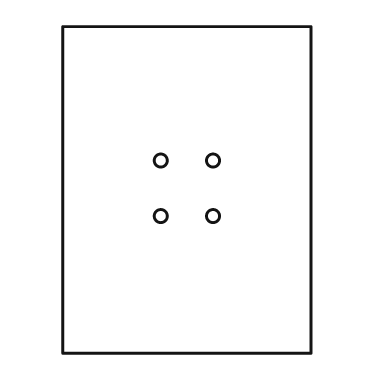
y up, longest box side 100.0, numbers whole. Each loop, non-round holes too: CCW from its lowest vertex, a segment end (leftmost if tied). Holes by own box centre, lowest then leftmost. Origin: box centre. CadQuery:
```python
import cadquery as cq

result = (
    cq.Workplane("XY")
    .moveTo(-38.0, -50.0)
    .lineTo(38.0, -50.0)
    .lineTo(38.0, 50.0)
    .lineTo(-38.0, 50.0)
    .close()
    .moveTo(-8.0, -8.0)
    .circle(2.0)
    .moveTo(8.0, -8.0)
    .circle(2.0)
    .moveTo(-8.0, 9.0)
    .circle(2.0)
    .moveTo(8.0, 9.0)
    .circle(2.0)
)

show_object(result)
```